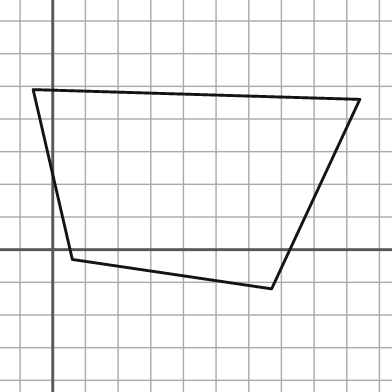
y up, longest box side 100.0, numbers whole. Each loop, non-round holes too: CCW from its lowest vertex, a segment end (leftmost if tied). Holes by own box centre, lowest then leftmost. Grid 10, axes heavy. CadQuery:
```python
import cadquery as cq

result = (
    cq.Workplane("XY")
    .moveTo(67.0, -12.0)
    .lineTo(94.0, 46.0)
    .lineTo(-6.0, 49.0)
    .lineTo(6.0, -3.0)
    .close()
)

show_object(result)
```